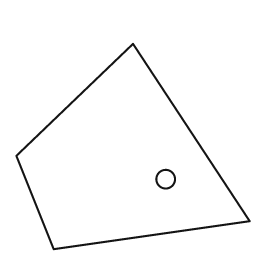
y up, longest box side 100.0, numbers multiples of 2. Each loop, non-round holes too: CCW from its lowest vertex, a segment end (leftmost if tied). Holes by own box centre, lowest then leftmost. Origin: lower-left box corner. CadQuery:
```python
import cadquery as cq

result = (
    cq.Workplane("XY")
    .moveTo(16.0, 0.0)
    .lineTo(100.0, 12.0)
    .lineTo(50.0, 88.0)
    .lineTo(0.0, 40.0)
    .close()
    .moveTo(64.0, 30.0)
    .circle(4.0)
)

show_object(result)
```